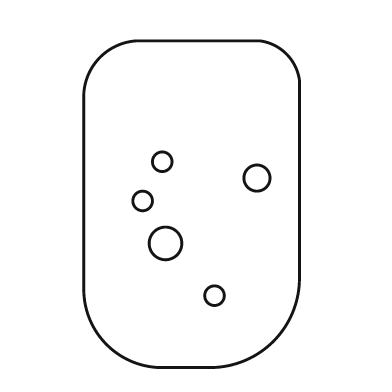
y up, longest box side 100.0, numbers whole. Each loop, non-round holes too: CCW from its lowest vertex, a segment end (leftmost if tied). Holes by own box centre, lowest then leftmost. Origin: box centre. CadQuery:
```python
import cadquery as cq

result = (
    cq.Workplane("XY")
    .moveTo(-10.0, -50.0)
    .lineTo(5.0, -50.0)
    .threePointArc((25.0, -42.0), (33.0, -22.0))
    .lineTo(33.0, 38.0)
    .threePointArc((29.0, 46.0), (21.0, 50.0))
    .lineTo(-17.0, 50.0)
    .threePointArc((-28.0, 45.0), (-33.0, 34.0))
    .lineTo(-33.0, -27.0)
    .threePointArc((-26.0, -43.0), (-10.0, -50.0))
    .close()
    .moveTo(7.0, -28.0)
    .circle(3.0)
    .moveTo(-8.0, -12.0)
    .circle(5.0)
    .moveTo(-15.0, 1.0)
    .circle(3.0)
    .moveTo(20.0, 8.0)
    .circle(4.0)
    .moveTo(-9.0, 13.0)
    .circle(3.0)
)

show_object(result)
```